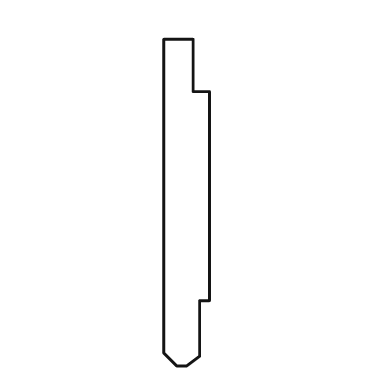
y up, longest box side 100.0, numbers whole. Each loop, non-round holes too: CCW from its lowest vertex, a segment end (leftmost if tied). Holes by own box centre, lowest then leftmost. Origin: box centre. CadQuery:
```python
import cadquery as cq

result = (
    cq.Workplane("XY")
    .moveTo(-3.0, -50.0)
    .lineTo(0.0, -50.0)
    .lineTo(4.0, -47.0)
    .lineTo(4.0, -30.0)
    .lineTo(7.0, -30.0)
    .lineTo(7.0, 34.0)
    .lineTo(2.0, 34.0)
    .lineTo(2.0, 50.0)
    .lineTo(-7.0, 50.0)
    .lineTo(-7.0, -46.0)
    .close()
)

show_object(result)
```